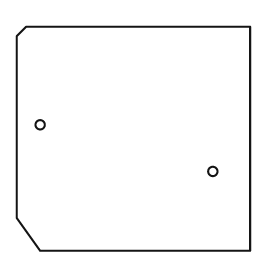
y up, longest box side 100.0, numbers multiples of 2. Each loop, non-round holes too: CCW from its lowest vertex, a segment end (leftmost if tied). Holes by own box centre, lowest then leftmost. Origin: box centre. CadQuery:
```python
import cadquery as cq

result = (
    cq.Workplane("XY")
    .moveTo(-40.0, -48.0)
    .lineTo(50.0, -48.0)
    .lineTo(50.0, 48.0)
    .lineTo(-46.0, 48.0)
    .lineTo(-50.0, 44.0)
    .lineTo(-50.0, -34.0)
    .close()
    .moveTo(34.0, -14.0)
    .circle(2.0)
    .moveTo(-40.0, 6.0)
    .circle(2.0)
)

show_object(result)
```